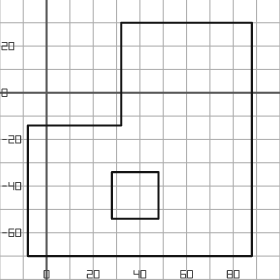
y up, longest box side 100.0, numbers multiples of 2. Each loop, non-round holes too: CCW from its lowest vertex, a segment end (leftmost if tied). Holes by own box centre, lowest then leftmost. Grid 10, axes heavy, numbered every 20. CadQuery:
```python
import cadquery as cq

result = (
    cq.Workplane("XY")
    .moveTo(-8.0, -70.0)
    .lineTo(88.0, -70.0)
    .lineTo(88.0, 30.0)
    .lineTo(32.0, 30.0)
    .lineTo(32.0, -14.0)
    .lineTo(-8.0, -14.0)
    .close()
    .moveTo(28.0, -54.0)
    .lineTo(48.0, -54.0)
    .lineTo(48.0, -34.0)
    .lineTo(28.0, -34.0)
    .close()
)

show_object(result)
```